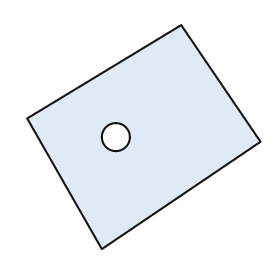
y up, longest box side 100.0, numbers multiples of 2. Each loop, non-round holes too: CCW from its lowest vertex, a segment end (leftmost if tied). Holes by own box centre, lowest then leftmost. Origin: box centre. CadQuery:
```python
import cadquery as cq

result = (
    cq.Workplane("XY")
    .moveTo(-18.0, -48.0)
    .lineTo(50.0, -2.0)
    .lineTo(16.0, 48.0)
    .lineTo(-50.0, 8.0)
    .close()
    .moveTo(-12.0, 0.0)
    .circle(6.0)
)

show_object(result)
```